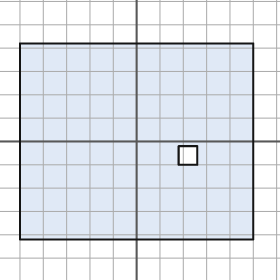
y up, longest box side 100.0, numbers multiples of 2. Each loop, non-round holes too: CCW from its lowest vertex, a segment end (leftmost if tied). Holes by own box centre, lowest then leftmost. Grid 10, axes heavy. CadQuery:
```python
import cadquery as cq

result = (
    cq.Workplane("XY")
    .moveTo(-50.0, -42.0)
    .lineTo(50.0, -42.0)
    .lineTo(50.0, 42.0)
    .lineTo(-50.0, 42.0)
    .close()
    .moveTo(18.0, -10.0)
    .lineTo(26.0, -10.0)
    .lineTo(26.0, -2.0)
    .lineTo(18.0, -2.0)
    .close()
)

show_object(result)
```